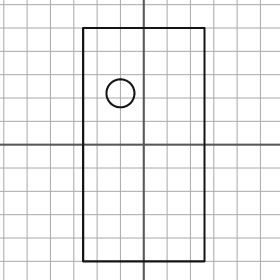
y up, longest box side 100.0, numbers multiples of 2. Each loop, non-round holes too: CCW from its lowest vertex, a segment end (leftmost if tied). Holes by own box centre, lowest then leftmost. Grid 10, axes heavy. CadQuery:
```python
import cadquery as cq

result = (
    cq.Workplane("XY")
    .moveTo(-26.0, -50.0)
    .lineTo(26.0, -50.0)
    .lineTo(26.0, 50.0)
    .lineTo(-26.0, 50.0)
    .close()
    .moveTo(-10.0, 22.0)
    .circle(6.0)
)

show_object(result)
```